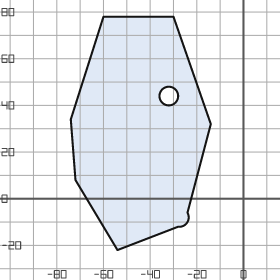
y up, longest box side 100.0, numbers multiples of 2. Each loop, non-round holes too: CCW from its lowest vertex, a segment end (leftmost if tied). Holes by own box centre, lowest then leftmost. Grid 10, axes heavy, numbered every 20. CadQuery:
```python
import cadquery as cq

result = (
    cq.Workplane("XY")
    .moveTo(-54.0, -22.0)
    .lineTo(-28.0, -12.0)
    .threePointArc((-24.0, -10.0), (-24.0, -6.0))
    .lineTo(-14.0, 32.0)
    .lineTo(-30.0, 78.0)
    .lineTo(-60.0, 78.0)
    .lineTo(-74.0, 34.0)
    .lineTo(-72.0, 8.0)
    .close()
    .moveTo(-32.0, 44.0)
    .circle(4.0)
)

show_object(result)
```